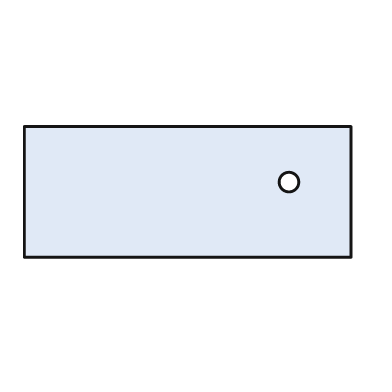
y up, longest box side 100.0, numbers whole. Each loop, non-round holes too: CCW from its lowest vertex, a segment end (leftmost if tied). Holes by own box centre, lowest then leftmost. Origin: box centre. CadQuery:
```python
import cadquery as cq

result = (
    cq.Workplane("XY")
    .moveTo(-50.0, -20.0)
    .lineTo(50.0, -20.0)
    .lineTo(50.0, 20.0)
    .lineTo(-50.0, 20.0)
    .close()
    .moveTo(31.0, 3.0)
    .circle(3.0)
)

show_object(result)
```